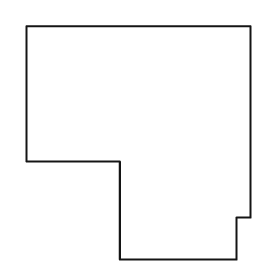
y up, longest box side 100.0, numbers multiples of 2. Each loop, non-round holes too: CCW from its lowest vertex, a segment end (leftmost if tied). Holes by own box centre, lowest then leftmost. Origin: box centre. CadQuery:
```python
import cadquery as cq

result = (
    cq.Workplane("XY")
    .moveTo(-8.0, -50.0)
    .lineTo(42.0, -50.0)
    .lineTo(42.0, -32.0)
    .lineTo(48.0, -32.0)
    .lineTo(48.0, 50.0)
    .lineTo(-48.0, 50.0)
    .lineTo(-48.0, -8.0)
    .lineTo(-8.0, -8.0)
    .close()
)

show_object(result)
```